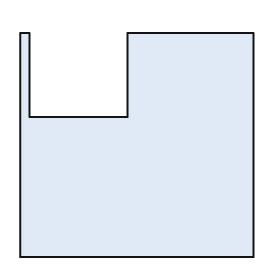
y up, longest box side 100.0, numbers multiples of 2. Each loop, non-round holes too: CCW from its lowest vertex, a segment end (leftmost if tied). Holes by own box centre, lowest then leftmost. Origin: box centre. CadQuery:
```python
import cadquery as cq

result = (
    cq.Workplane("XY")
    .moveTo(-50.0, -48.0)
    .lineTo(50.0, -48.0)
    .lineTo(50.0, 48.0)
    .lineTo(-4.0, 48.0)
    .lineTo(-4.0, 12.0)
    .lineTo(-46.0, 12.0)
    .lineTo(-46.0, 48.0)
    .lineTo(-50.0, 48.0)
    .close()
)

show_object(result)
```